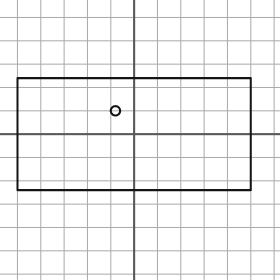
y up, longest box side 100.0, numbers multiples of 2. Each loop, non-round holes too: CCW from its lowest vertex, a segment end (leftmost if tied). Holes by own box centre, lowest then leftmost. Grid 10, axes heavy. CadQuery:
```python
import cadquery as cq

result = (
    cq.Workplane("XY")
    .moveTo(-50.0, -24.0)
    .lineTo(50.0, -24.0)
    .lineTo(50.0, 24.0)
    .lineTo(-50.0, 24.0)
    .close()
    .moveTo(-8.0, 10.0)
    .circle(2.0)
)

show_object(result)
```